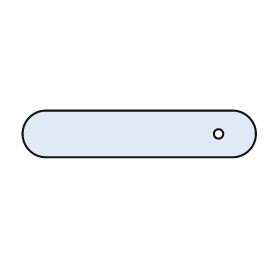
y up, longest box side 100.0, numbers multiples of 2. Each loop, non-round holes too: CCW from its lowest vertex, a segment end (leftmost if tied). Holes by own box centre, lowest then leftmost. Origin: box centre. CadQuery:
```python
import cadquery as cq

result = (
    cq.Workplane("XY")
    .moveTo(-40.0, -10.0)
    .lineTo(40.0, -10.0)
    .threePointArc((50.0, 0.0), (40.0, 10.0))
    .lineTo(-40.0, 10.0)
    .threePointArc((-50.0, 0.0), (-40.0, -10.0))
    .close()
    .moveTo(34.0, 0.0)
    .circle(2.0)
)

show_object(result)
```